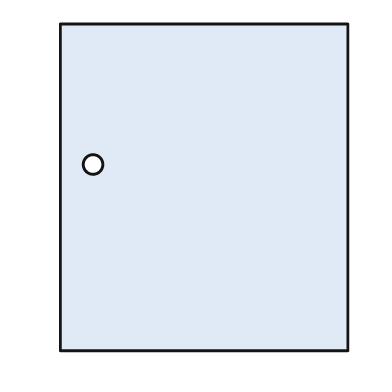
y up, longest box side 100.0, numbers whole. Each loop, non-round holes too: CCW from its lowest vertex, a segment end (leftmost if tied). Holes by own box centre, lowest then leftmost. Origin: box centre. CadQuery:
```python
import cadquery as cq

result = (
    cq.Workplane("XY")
    .moveTo(-44.0, -50.0)
    .lineTo(44.0, -50.0)
    .lineTo(44.0, 50.0)
    .lineTo(-44.0, 50.0)
    .close()
    .moveTo(-34.0, 7.0)
    .circle(3.0)
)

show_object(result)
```